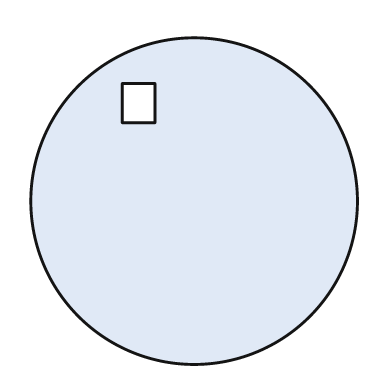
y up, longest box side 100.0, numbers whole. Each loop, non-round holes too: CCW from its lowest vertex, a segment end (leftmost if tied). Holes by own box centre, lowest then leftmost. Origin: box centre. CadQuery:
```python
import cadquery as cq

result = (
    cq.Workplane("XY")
    .moveTo(0.0, 0.0)
    .circle(50.0)
    .moveTo(-22.0, 24.0)
    .lineTo(-12.0, 24.0)
    .lineTo(-12.0, 36.0)
    .lineTo(-22.0, 36.0)
    .close()
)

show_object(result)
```